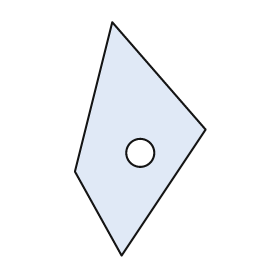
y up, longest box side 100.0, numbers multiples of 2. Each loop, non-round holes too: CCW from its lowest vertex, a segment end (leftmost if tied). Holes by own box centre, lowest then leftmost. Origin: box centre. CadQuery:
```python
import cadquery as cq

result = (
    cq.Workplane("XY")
    .moveTo(-8.0, -50.0)
    .lineTo(28.0, 4.0)
    .lineTo(-12.0, 50.0)
    .lineTo(-28.0, -14.0)
    .close()
    .moveTo(0.0, -6.0)
    .circle(6.0)
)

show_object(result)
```